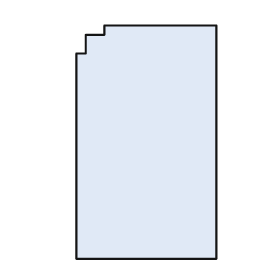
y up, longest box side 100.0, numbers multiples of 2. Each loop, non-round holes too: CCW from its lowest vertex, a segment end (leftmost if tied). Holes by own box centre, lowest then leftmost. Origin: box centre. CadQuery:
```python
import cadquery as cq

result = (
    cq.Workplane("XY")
    .moveTo(-30.0, -50.0)
    .lineTo(30.0, -50.0)
    .lineTo(30.0, 50.0)
    .lineTo(-18.0, 50.0)
    .lineTo(-18.0, 46.0)
    .lineTo(-26.0, 46.0)
    .lineTo(-26.0, 38.0)
    .lineTo(-30.0, 38.0)
    .close()
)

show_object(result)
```